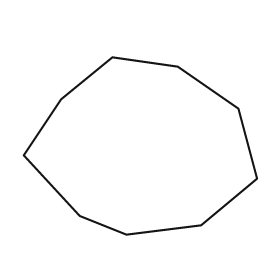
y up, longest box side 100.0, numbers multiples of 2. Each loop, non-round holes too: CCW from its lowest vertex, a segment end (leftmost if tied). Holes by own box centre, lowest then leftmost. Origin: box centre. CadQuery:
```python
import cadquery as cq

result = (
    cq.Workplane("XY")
    .moveTo(-6.0, -38.0)
    .lineTo(26.0, -34.0)
    .lineTo(50.0, -14.0)
    .lineTo(42.0, 16.0)
    .lineTo(16.0, 34.0)
    .lineTo(-12.0, 38.0)
    .lineTo(-34.0, 20.0)
    .lineTo(-50.0, -4.0)
    .lineTo(-26.0, -30.0)
    .close()
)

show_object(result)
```